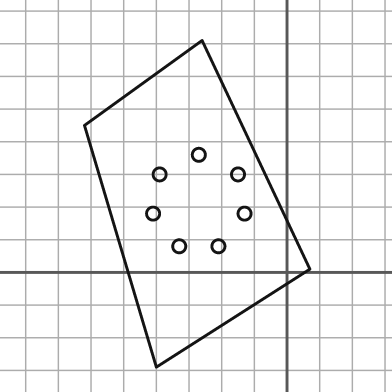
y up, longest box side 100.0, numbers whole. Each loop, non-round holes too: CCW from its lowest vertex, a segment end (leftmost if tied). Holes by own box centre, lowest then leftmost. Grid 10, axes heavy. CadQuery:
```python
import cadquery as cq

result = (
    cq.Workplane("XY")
    .moveTo(-40.0, -29.0)
    .lineTo(7.0, 1.0)
    .lineTo(-26.0, 71.0)
    .lineTo(-62.0, 45.0)
    .close()
    .moveTo(-33.0, 8.0)
    .circle(2.0)
    .moveTo(-21.0, 8.0)
    .circle(2.0)
    .moveTo(-41.0, 18.0)
    .circle(2.0)
    .moveTo(-13.0, 18.0)
    .circle(2.0)
    .moveTo(-39.0, 30.0)
    .circle(2.0)
    .moveTo(-15.0, 30.0)
    .circle(2.0)
    .moveTo(-27.0, 36.0)
    .circle(2.0)
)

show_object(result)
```